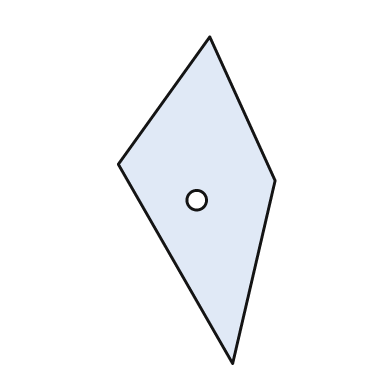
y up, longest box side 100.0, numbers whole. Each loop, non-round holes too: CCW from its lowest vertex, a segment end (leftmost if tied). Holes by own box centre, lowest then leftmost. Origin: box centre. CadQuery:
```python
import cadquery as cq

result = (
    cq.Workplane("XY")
    .moveTo(11.0, -50.0)
    .lineTo(24.0, 6.0)
    .lineTo(4.0, 50.0)
    .lineTo(-24.0, 11.0)
    .close()
    .moveTo(0.0, 0.0)
    .circle(3.0)
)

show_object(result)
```